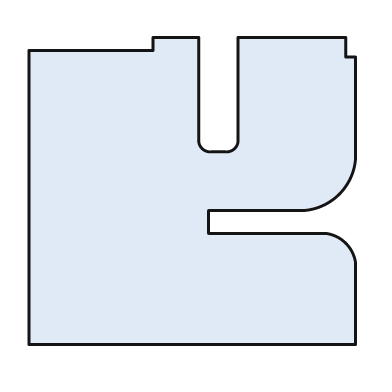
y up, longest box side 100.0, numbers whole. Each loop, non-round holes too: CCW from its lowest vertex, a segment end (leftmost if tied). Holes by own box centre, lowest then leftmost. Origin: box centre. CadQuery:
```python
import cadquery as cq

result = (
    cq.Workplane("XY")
    .moveTo(-50.0, -47.0)
    .lineTo(50.0, -47.0)
    .lineTo(50.0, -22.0)
    .threePointArc((47.0, -16.0), (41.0, -13.0))
    .lineTo(5.0, -13.0)
    .lineTo(5.0, -6.0)
    .lineTo(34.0, -6.0)
    .threePointArc((45.0, -1.0), (50.0, 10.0))
    .lineTo(50.0, 41.0)
    .lineTo(47.0, 41.0)
    .lineTo(47.0, 47.0)
    .lineTo(14.0, 47.0)
    .lineTo(14.0, 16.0)
    .threePointArc((13.0, 13.0), (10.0, 12.0))
    .lineTo(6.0, 12.0)
    .threePointArc((3.0, 13.0), (2.0, 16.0))
    .lineTo(2.0, 47.0)
    .lineTo(-12.0, 47.0)
    .lineTo(-12.0, 43.0)
    .lineTo(-50.0, 43.0)
    .close()
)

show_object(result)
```